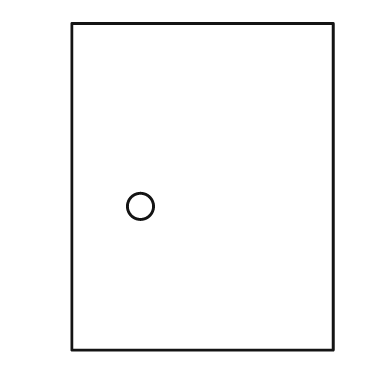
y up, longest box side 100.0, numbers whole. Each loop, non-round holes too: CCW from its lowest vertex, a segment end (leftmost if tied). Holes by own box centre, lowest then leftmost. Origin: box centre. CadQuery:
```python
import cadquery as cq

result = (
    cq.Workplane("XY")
    .moveTo(-40.0, -50.0)
    .lineTo(40.0, -50.0)
    .lineTo(40.0, 50.0)
    .lineTo(-40.0, 50.0)
    .close()
    .moveTo(-19.0, -6.0)
    .circle(4.0)
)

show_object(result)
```